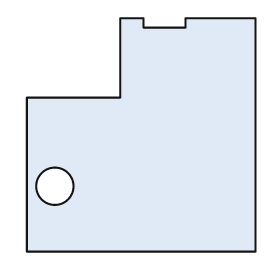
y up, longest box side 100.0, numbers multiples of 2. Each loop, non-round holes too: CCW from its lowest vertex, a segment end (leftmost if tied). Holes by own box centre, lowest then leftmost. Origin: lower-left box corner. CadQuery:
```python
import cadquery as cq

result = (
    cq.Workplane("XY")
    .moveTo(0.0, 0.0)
    .lineTo(98.0, 0.0)
    .lineTo(98.0, 100.0)
    .lineTo(68.0, 100.0)
    .lineTo(68.0, 96.0)
    .lineTo(50.0, 96.0)
    .lineTo(50.0, 100.0)
    .lineTo(40.0, 100.0)
    .lineTo(40.0, 66.0)
    .lineTo(0.0, 66.0)
    .close()
    .moveTo(12.0, 28.0)
    .circle(8.0)
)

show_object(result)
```